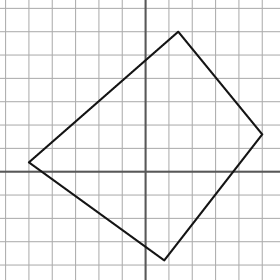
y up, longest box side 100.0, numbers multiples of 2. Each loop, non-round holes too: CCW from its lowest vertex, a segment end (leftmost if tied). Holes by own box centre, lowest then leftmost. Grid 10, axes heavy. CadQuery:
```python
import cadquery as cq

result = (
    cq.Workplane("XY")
    .moveTo(8.0, -38.0)
    .lineTo(50.0, 16.0)
    .lineTo(14.0, 60.0)
    .lineTo(-50.0, 4.0)
    .close()
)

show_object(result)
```